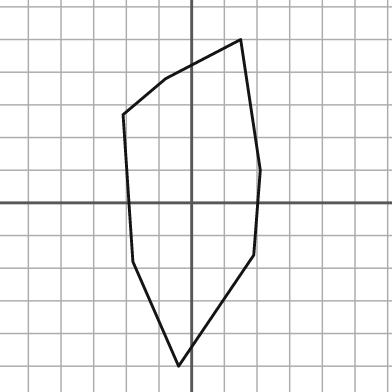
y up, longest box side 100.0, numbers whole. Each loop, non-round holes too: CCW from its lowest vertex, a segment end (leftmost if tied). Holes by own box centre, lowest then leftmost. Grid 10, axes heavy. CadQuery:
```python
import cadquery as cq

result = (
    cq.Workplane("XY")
    .moveTo(-4.0, -50.0)
    .lineTo(19.0, -16.0)
    .lineTo(21.0, 10.0)
    .lineTo(15.0, 50.0)
    .lineTo(-8.0, 38.0)
    .lineTo(-21.0, 27.0)
    .lineTo(-18.0, -18.0)
    .close()
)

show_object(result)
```